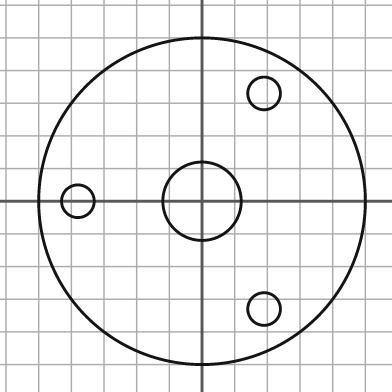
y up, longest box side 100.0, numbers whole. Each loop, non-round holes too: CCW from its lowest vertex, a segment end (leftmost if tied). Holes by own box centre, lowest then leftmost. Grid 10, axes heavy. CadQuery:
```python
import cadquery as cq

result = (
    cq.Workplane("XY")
    .moveTo(0.0, 0.0)
    .circle(50.0)
    .moveTo(19.0, -33.0)
    .circle(5.0)
    .moveTo(-38.0, 0.0)
    .circle(5.0)
    .moveTo(0.0, 0.0)
    .circle(12.0)
    .moveTo(19.0, 33.0)
    .circle(5.0)
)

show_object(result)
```